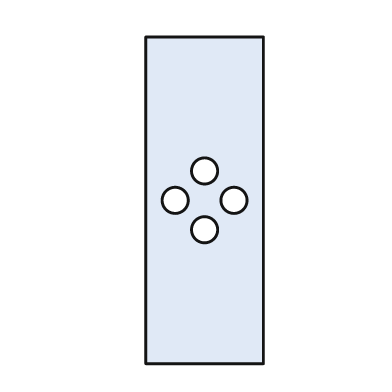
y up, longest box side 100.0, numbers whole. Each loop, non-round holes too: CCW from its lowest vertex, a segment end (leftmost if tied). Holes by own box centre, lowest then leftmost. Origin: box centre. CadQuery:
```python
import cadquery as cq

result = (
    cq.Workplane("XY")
    .moveTo(-18.0, -50.0)
    .lineTo(18.0, -50.0)
    .lineTo(18.0, 50.0)
    .lineTo(-18.0, 50.0)
    .close()
    .moveTo(0.0, -9.0)
    .circle(4.0)
    .moveTo(-9.0, 0.0)
    .circle(4.0)
    .moveTo(9.0, 0.0)
    .circle(4.0)
    .moveTo(0.0, 9.0)
    .circle(4.0)
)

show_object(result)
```